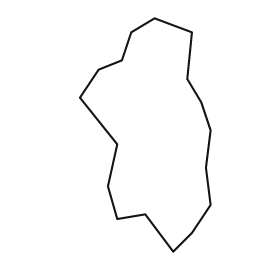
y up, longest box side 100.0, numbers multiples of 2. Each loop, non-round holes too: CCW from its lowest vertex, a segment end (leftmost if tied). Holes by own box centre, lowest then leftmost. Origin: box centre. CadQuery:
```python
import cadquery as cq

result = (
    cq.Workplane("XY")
    .moveTo(12.0, -50.0)
    .lineTo(20.0, -42.0)
    .lineTo(28.0, -30.0)
    .lineTo(26.0, -14.0)
    .lineTo(28.0, 2.0)
    .lineTo(24.0, 14.0)
    .lineTo(18.0, 24.0)
    .lineTo(20.0, 44.0)
    .lineTo(4.0, 50.0)
    .lineTo(-6.0, 44.0)
    .lineTo(-10.0, 32.0)
    .lineTo(-20.0, 28.0)
    .lineTo(-28.0, 16.0)
    .lineTo(-12.0, -4.0)
    .lineTo(-16.0, -22.0)
    .lineTo(-12.0, -36.0)
    .lineTo(0.0, -34.0)
    .close()
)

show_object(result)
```